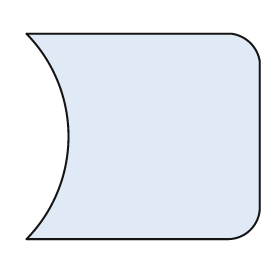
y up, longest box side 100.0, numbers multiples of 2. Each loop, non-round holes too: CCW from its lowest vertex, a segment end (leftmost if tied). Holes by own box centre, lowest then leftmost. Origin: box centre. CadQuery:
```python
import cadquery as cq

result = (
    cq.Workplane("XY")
    .moveTo(-50.0, -44.0)
    .lineTo(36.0, -44.0)
    .threePointArc((46.0, -40.0), (50.0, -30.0))
    .lineTo(50.0, 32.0)
    .threePointArc((46.0, 40.0), (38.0, 44.0))
    .lineTo(-50.0, 44.0)
    .threePointArc((-32.0, 0.0), (-50.0, -44.0))
    .close()
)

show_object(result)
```